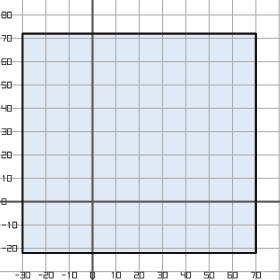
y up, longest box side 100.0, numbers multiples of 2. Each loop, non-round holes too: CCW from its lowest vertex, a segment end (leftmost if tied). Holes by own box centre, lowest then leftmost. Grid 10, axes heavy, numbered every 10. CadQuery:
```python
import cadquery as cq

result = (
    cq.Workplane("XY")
    .moveTo(-30.0, -22.0)
    .lineTo(70.0, -22.0)
    .lineTo(70.0, 72.0)
    .lineTo(-30.0, 72.0)
    .close()
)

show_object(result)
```